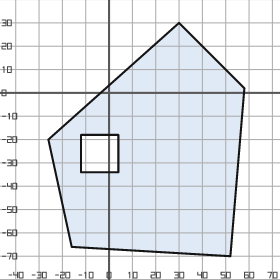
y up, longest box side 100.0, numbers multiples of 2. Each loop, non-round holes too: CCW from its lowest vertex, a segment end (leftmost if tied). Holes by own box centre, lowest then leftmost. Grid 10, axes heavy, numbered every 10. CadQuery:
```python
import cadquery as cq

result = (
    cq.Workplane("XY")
    .moveTo(52.0, -70.0)
    .lineTo(58.0, 2.0)
    .lineTo(30.0, 30.0)
    .lineTo(-26.0, -20.0)
    .lineTo(-16.0, -66.0)
    .close()
    .moveTo(-12.0, -34.0)
    .lineTo(4.0, -34.0)
    .lineTo(4.0, -18.0)
    .lineTo(-12.0, -18.0)
    .close()
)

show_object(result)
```